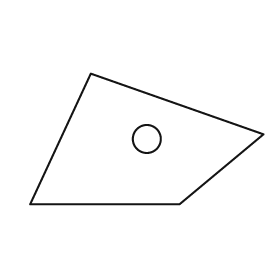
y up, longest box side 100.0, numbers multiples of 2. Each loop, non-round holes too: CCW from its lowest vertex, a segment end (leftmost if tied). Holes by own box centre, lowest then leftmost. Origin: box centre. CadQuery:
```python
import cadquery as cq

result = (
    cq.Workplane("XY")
    .moveTo(-50.0, -28.0)
    .lineTo(14.0, -28.0)
    .lineTo(50.0, 2.0)
    .lineTo(-24.0, 28.0)
    .close()
    .moveTo(0.0, 0.0)
    .circle(6.0)
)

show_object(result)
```